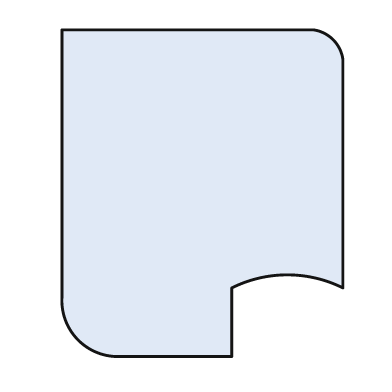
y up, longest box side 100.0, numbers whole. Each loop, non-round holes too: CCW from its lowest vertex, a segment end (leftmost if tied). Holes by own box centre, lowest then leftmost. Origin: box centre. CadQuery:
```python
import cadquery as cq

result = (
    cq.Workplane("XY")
    .moveTo(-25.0, -50.0)
    .lineTo(9.0, -50.0)
    .lineTo(9.0, -29.0)
    .threePointArc((26.0, -25.0), (43.0, -29.0))
    .lineTo(43.0, 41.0)
    .threePointArc((40.0, 47.0), (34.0, 50.0))
    .lineTo(-43.0, 50.0)
    .lineTo(-43.0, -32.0)
    .threePointArc((-38.0, -45.0), (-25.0, -50.0))
    .close()
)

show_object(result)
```